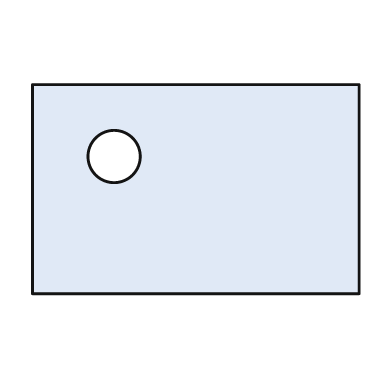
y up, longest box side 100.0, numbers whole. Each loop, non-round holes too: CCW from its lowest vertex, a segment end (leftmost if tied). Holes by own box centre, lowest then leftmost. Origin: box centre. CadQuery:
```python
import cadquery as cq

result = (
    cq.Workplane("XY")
    .moveTo(-50.0, -32.0)
    .lineTo(50.0, -32.0)
    .lineTo(50.0, 32.0)
    .lineTo(-50.0, 32.0)
    .close()
    .moveTo(-25.0, 10.0)
    .circle(8.0)
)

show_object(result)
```